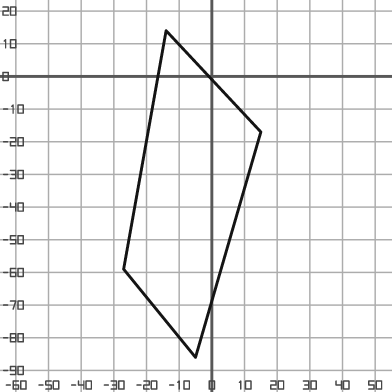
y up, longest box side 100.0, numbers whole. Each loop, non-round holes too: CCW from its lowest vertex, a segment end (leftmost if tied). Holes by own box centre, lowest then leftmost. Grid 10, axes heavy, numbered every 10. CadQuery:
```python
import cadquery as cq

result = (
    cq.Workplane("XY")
    .moveTo(-5.0, -86.0)
    .lineTo(15.0, -17.0)
    .lineTo(-14.0, 14.0)
    .lineTo(-27.0, -59.0)
    .close()
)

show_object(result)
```